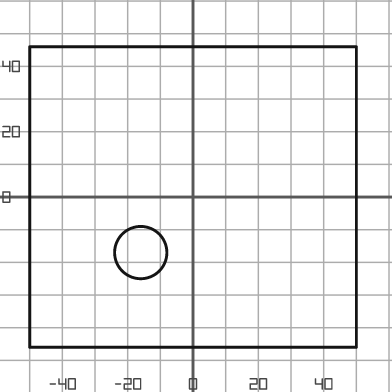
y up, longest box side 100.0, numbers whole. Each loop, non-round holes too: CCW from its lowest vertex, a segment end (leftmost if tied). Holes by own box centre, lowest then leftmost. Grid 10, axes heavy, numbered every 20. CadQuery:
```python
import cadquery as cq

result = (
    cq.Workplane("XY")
    .moveTo(-50.0, -46.0)
    .lineTo(50.0, -46.0)
    .lineTo(50.0, 46.0)
    .lineTo(-50.0, 46.0)
    .close()
    .moveTo(-16.0, -17.0)
    .circle(8.0)
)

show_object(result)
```